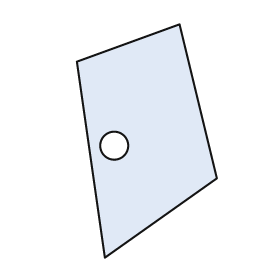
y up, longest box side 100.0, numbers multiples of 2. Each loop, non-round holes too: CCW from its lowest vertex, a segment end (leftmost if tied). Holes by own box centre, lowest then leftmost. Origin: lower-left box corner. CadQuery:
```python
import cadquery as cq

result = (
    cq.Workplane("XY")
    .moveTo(12.0, 0.0)
    .lineTo(60.0, 34.0)
    .lineTo(44.0, 100.0)
    .lineTo(0.0, 84.0)
    .close()
    .moveTo(16.0, 48.0)
    .circle(6.0)
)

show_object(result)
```